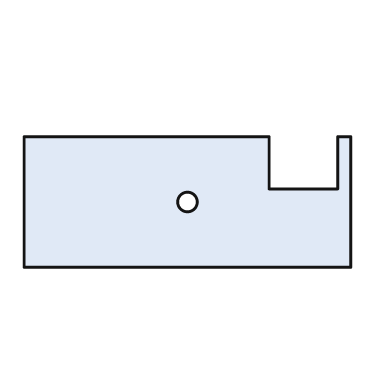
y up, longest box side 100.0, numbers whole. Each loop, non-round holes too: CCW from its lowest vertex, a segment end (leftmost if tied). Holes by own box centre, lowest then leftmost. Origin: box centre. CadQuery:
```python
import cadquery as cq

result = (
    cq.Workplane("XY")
    .moveTo(-50.0, -20.0)
    .lineTo(50.0, -20.0)
    .lineTo(50.0, 20.0)
    .lineTo(46.0, 20.0)
    .lineTo(46.0, 4.0)
    .lineTo(25.0, 4.0)
    .lineTo(25.0, 20.0)
    .lineTo(-50.0, 20.0)
    .close()
    .moveTo(0.0, 0.0)
    .circle(3.0)
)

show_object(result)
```